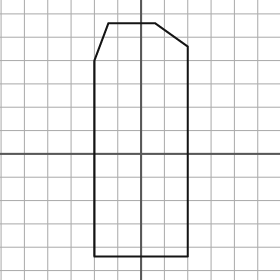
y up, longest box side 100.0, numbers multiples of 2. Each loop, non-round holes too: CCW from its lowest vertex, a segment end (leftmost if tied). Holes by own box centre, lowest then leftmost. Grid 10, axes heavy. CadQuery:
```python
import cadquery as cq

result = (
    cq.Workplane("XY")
    .moveTo(-20.0, -44.0)
    .lineTo(20.0, -44.0)
    .lineTo(20.0, 46.0)
    .lineTo(6.0, 56.0)
    .lineTo(-14.0, 56.0)
    .lineTo(-20.0, 40.0)
    .close()
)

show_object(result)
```